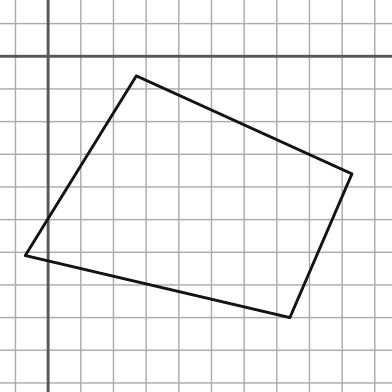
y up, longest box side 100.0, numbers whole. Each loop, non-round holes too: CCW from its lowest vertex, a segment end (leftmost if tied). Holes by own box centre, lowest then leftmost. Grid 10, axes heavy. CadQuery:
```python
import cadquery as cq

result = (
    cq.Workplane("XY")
    .moveTo(74.0, -80.0)
    .lineTo(93.0, -36.0)
    .lineTo(27.0, -6.0)
    .lineTo(-7.0, -61.0)
    .close()
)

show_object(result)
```